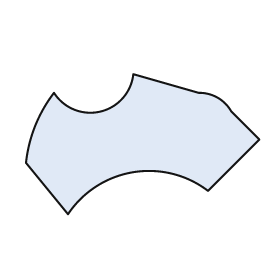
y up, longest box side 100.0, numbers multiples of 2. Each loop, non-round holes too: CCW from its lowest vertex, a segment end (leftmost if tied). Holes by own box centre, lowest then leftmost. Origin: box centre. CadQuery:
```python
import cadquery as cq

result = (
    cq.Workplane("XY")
    .moveTo(-32.0, -30.0)
    .threePointArc((-4.0, -12.0), (28.0, -20.0))
    .lineTo(50.0, 2.0)
    .lineTo(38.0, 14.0)
    .threePointArc((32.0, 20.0), (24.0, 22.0))
    .lineTo(-4.0, 30.0)
    .threePointArc((-18.0, 14.0), (-38.0, 22.0))
    .threePointArc((-46.0, 8.0), (-50.0, -8.0))
    .close()
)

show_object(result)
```